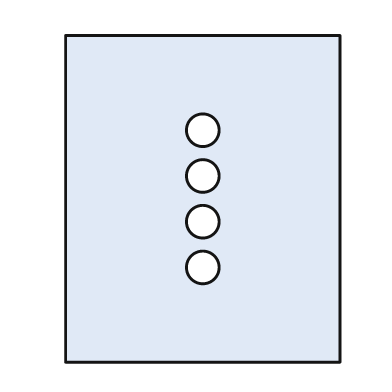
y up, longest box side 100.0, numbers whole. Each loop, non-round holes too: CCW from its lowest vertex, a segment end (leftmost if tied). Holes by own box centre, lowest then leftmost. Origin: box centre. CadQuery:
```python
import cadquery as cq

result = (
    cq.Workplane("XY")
    .moveTo(-42.0, -50.0)
    .lineTo(42.0, -50.0)
    .lineTo(42.0, 50.0)
    .lineTo(-42.0, 50.0)
    .close()
    .moveTo(0.0, -21.0)
    .circle(5.0)
    .moveTo(0.0, -7.0)
    .circle(5.0)
    .moveTo(0.0, 7.0)
    .circle(5.0)
    .moveTo(0.0, 21.0)
    .circle(5.0)
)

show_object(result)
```